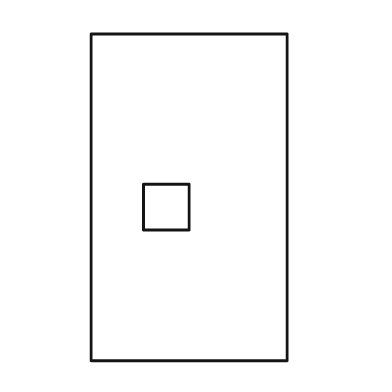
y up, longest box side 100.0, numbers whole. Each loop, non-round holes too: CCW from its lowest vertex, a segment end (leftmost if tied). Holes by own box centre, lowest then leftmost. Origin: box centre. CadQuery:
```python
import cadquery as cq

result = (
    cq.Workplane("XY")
    .moveTo(-30.0, -50.0)
    .lineTo(30.0, -50.0)
    .lineTo(30.0, 50.0)
    .lineTo(-30.0, 50.0)
    .close()
    .moveTo(-14.0, -10.0)
    .lineTo(0.0, -10.0)
    .lineTo(0.0, 4.0)
    .lineTo(-14.0, 4.0)
    .close()
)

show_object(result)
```